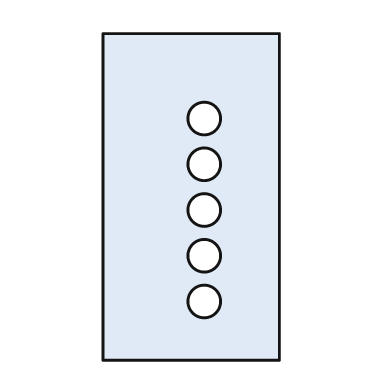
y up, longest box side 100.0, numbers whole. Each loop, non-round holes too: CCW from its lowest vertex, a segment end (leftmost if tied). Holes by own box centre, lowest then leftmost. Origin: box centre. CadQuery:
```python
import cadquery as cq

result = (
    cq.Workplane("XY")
    .moveTo(-27.0, -50.0)
    .lineTo(27.0, -50.0)
    .lineTo(27.0, 50.0)
    .lineTo(-27.0, 50.0)
    .close()
    .moveTo(4.0, -32.0)
    .circle(5.0)
    .moveTo(4.0, -18.0)
    .circle(5.0)
    .moveTo(4.0, -4.0)
    .circle(5.0)
    .moveTo(4.0, 10.0)
    .circle(5.0)
    .moveTo(4.0, 24.0)
    .circle(5.0)
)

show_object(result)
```